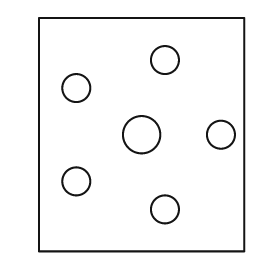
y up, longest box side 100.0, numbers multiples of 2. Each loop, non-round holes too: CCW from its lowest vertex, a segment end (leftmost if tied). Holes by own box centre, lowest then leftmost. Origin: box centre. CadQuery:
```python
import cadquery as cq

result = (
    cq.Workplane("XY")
    .moveTo(-44.0, -50.0)
    .lineTo(44.0, -50.0)
    .lineTo(44.0, 50.0)
    .lineTo(-44.0, 50.0)
    .close()
    .moveTo(10.0, -32.0)
    .circle(6.0)
    .moveTo(-28.0, -20.0)
    .circle(6.0)
    .moveTo(0.0, 0.0)
    .circle(8.0)
    .moveTo(34.0, 0.0)
    .circle(6.0)
    .moveTo(-28.0, 20.0)
    .circle(6.0)
    .moveTo(10.0, 32.0)
    .circle(6.0)
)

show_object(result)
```